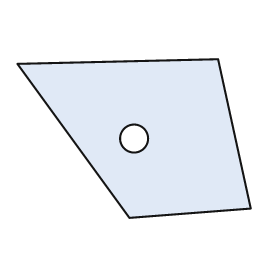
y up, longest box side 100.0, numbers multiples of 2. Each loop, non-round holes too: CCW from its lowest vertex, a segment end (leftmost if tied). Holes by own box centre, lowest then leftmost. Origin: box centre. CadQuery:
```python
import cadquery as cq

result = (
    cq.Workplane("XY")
    .moveTo(-2.0, -34.0)
    .lineTo(50.0, -30.0)
    .lineTo(36.0, 34.0)
    .lineTo(-50.0, 32.0)
    .close()
    .moveTo(0.0, 0.0)
    .circle(6.0)
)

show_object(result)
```